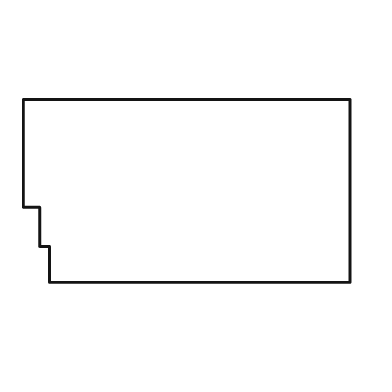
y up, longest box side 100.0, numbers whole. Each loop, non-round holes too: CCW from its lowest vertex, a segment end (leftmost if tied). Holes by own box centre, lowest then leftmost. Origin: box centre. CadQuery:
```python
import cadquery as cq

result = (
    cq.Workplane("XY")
    .moveTo(-42.0, -28.0)
    .lineTo(50.0, -28.0)
    .lineTo(50.0, 28.0)
    .lineTo(-50.0, 28.0)
    .lineTo(-50.0, -5.0)
    .lineTo(-45.0, -5.0)
    .lineTo(-45.0, -17.0)
    .lineTo(-42.0, -17.0)
    .close()
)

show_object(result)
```